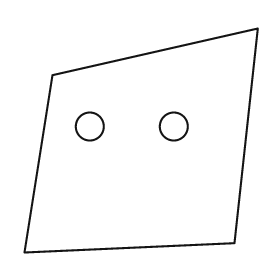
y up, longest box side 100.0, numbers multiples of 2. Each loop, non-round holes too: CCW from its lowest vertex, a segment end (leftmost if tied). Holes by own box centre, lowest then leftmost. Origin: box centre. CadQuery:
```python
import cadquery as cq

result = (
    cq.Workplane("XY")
    .moveTo(-50.0, -48.0)
    .lineTo(40.0, -44.0)
    .lineTo(50.0, 48.0)
    .lineTo(-38.0, 28.0)
    .close()
    .moveTo(-22.0, 6.0)
    .circle(6.0)
    .moveTo(14.0, 6.0)
    .circle(6.0)
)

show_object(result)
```